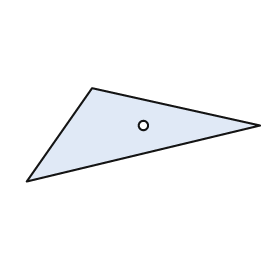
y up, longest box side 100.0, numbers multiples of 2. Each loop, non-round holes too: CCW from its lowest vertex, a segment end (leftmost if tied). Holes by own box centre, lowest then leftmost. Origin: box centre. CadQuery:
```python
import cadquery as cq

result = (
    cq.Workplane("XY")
    .moveTo(-50.0, -20.0)
    .lineTo(50.0, 4.0)
    .lineTo(-22.0, 20.0)
    .close()
    .moveTo(0.0, 4.0)
    .circle(2.0)
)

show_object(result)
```